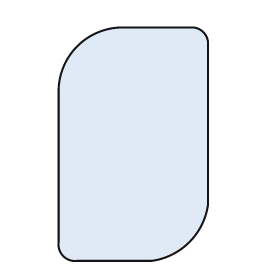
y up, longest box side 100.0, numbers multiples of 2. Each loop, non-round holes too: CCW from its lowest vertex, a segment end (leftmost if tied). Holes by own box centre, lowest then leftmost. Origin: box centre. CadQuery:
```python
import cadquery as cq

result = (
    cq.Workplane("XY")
    .moveTo(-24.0, -50.0)
    .lineTo(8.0, -50.0)
    .threePointArc((24.0, -42.0), (32.0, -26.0))
    .lineTo(32.0, 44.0)
    .threePointArc((30.0, 48.0), (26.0, 50.0))
    .lineTo(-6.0, 50.0)
    .threePointArc((-24.0, 42.0), (-32.0, 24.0))
    .lineTo(-32.0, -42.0)
    .threePointArc((-30.0, -48.0), (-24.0, -50.0))
    .close()
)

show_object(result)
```